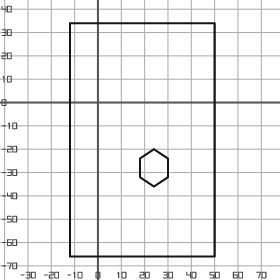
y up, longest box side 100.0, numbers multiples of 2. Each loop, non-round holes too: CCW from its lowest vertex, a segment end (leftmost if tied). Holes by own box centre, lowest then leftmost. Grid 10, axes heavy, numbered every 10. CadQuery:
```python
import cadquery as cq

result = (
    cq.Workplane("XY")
    .moveTo(-12.0, -66.0)
    .lineTo(50.0, -66.0)
    .lineTo(50.0, 34.0)
    .lineTo(-12.0, 34.0)
    .close()
    .moveTo(24.0, -36.0)
    .lineTo(30.0, -32.0)
    .lineTo(30.0, -24.0)
    .lineTo(24.0, -20.0)
    .lineTo(18.0, -24.0)
    .lineTo(18.0, -32.0)
    .close()
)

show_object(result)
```